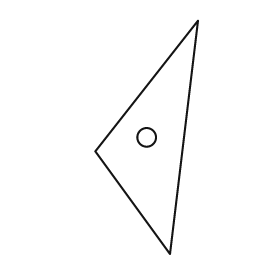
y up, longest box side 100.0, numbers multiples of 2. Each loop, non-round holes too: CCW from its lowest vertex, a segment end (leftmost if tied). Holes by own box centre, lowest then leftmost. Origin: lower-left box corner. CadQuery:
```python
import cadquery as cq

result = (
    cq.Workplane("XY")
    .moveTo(32.0, 0.0)
    .lineTo(44.0, 100.0)
    .lineTo(0.0, 44.0)
    .close()
    .moveTo(22.0, 50.0)
    .circle(4.0)
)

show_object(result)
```